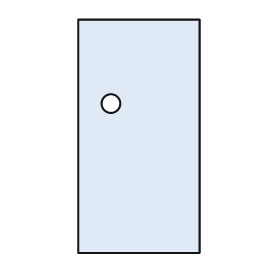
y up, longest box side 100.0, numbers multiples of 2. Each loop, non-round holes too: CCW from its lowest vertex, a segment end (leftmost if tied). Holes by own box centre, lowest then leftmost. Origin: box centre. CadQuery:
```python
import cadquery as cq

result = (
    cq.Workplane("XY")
    .moveTo(-26.0, -50.0)
    .lineTo(26.0, -50.0)
    .lineTo(26.0, 50.0)
    .lineTo(-26.0, 50.0)
    .close()
    .moveTo(-12.0, 14.0)
    .circle(4.0)
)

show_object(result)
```